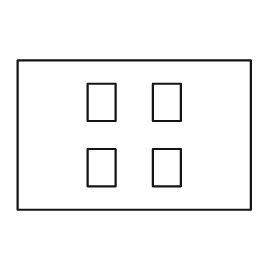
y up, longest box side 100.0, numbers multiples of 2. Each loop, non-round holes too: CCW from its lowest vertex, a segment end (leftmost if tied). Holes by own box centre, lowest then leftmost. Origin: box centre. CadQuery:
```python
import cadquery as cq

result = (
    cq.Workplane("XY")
    .moveTo(-50.0, -32.0)
    .lineTo(50.0, -32.0)
    .lineTo(50.0, 32.0)
    .lineTo(-50.0, 32.0)
    .close()
    .moveTo(-20.0, -22.0)
    .lineTo(-8.0, -22.0)
    .lineTo(-8.0, -6.0)
    .lineTo(-20.0, -6.0)
    .close()
    .moveTo(8.0, -22.0)
    .lineTo(20.0, -22.0)
    .lineTo(20.0, -6.0)
    .lineTo(8.0, -6.0)
    .close()
    .moveTo(-20.0, 6.0)
    .lineTo(-8.0, 6.0)
    .lineTo(-8.0, 22.0)
    .lineTo(-20.0, 22.0)
    .close()
    .moveTo(8.0, 6.0)
    .lineTo(20.0, 6.0)
    .lineTo(20.0, 22.0)
    .lineTo(8.0, 22.0)
    .close()
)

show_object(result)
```